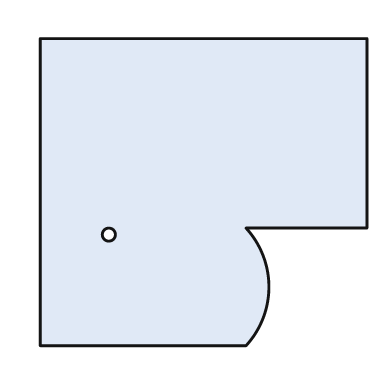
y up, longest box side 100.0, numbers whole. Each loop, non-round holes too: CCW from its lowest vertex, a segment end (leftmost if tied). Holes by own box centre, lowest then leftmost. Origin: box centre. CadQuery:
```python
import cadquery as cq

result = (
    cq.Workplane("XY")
    .moveTo(-50.0, -47.0)
    .lineTo(13.0, -47.0)
    .threePointArc((20.0, -29.0), (13.0, -11.0))
    .lineTo(50.0, -11.0)
    .lineTo(50.0, 47.0)
    .lineTo(-50.0, 47.0)
    .close()
    .moveTo(-29.0, -13.0)
    .circle(2.0)
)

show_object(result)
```